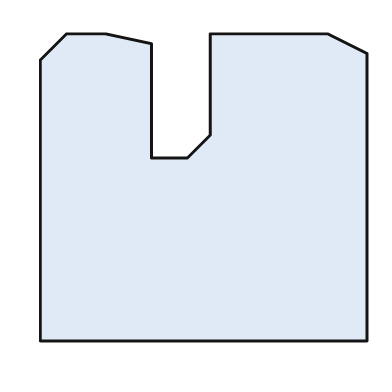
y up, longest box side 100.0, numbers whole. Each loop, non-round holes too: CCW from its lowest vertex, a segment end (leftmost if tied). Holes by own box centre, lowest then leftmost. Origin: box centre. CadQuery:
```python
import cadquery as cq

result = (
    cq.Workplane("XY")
    .moveTo(-50.0, -47.0)
    .lineTo(50.0, -47.0)
    .lineTo(50.0, 41.0)
    .lineTo(38.0, 47.0)
    .lineTo(2.0, 47.0)
    .lineTo(2.0, 16.0)
    .lineTo(-5.0, 9.0)
    .lineTo(-16.0, 9.0)
    .lineTo(-16.0, 44.0)
    .lineTo(-30.0, 47.0)
    .lineTo(-42.0, 47.0)
    .lineTo(-50.0, 39.0)
    .close()
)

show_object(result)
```